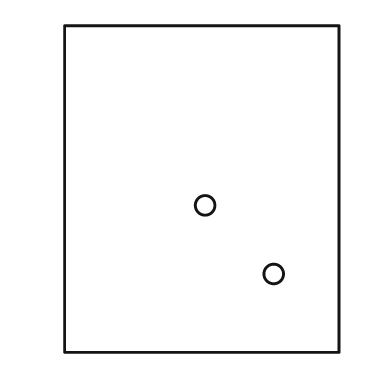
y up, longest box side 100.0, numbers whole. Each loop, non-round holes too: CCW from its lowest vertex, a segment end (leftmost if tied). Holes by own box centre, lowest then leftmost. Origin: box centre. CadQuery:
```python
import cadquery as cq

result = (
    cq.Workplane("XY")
    .moveTo(-42.0, -50.0)
    .lineTo(42.0, -50.0)
    .lineTo(42.0, 50.0)
    .lineTo(-42.0, 50.0)
    .close()
    .moveTo(22.0, -26.0)
    .circle(3.0)
    .moveTo(1.0, -5.0)
    .circle(3.0)
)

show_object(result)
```